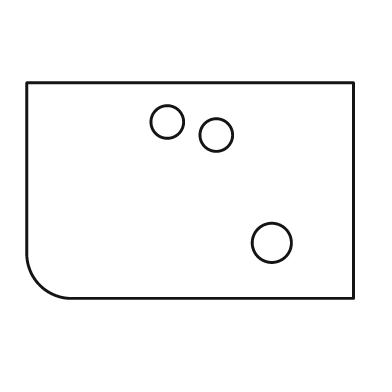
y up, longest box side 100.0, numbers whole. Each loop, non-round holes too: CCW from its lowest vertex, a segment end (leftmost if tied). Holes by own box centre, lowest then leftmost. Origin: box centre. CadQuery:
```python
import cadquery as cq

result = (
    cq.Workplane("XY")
    .moveTo(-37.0, -33.0)
    .lineTo(50.0, -33.0)
    .lineTo(50.0, 33.0)
    .lineTo(-50.0, 33.0)
    .lineTo(-50.0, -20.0)
    .threePointArc((-46.0, -29.0), (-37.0, -33.0))
    .close()
    .moveTo(25.0, -16.0)
    .circle(6.0)
    .moveTo(8.0, 17.0)
    .circle(5.0)
    .moveTo(-7.0, 21.0)
    .circle(5.0)
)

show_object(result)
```